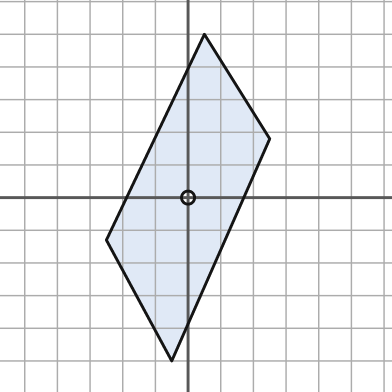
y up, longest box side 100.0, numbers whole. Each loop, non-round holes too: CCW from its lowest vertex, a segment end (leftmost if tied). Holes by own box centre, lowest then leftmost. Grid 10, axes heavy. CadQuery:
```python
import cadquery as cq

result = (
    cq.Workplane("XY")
    .moveTo(-5.0, -50.0)
    .lineTo(25.0, 18.0)
    .lineTo(5.0, 50.0)
    .lineTo(-25.0, -13.0)
    .close()
    .moveTo(0.0, 0.0)
    .circle(2.0)
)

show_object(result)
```